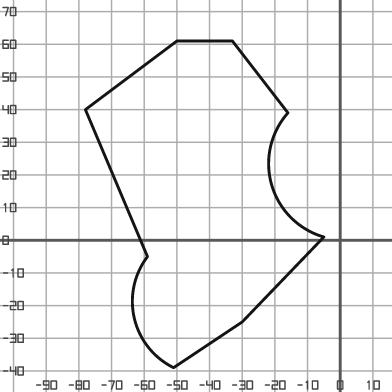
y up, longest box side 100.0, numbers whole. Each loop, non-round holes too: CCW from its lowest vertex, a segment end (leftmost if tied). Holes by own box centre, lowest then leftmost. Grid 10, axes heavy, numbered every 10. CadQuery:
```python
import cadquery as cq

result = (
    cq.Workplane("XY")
    .moveTo(-51.0, -39.0)
    .lineTo(-30.0, -25.0)
    .lineTo(-5.0, 1.0)
    .threePointArc((-21.0, 17.0), (-16.0, 39.0))
    .lineTo(-33.0, 61.0)
    .lineTo(-50.0, 61.0)
    .lineTo(-78.0, 40.0)
    .lineTo(-59.0, -5.0)
    .threePointArc((-63.0, -24.0), (-51.0, -39.0))
    .close()
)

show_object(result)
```